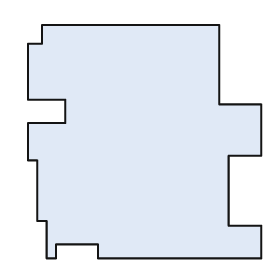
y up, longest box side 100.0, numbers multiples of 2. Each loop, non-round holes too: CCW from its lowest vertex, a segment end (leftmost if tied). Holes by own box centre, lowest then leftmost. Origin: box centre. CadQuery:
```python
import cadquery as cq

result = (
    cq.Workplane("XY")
    .moveTo(-42.0, -50.0)
    .lineTo(-38.0, -50.0)
    .lineTo(-38.0, -44.0)
    .lineTo(-20.0, -44.0)
    .lineTo(-20.0, -50.0)
    .lineTo(50.0, -50.0)
    .lineTo(50.0, -36.0)
    .lineTo(36.0, -36.0)
    .lineTo(36.0, -6.0)
    .lineTo(50.0, -6.0)
    .lineTo(50.0, 16.0)
    .lineTo(32.0, 16.0)
    .lineTo(32.0, 50.0)
    .lineTo(-44.0, 50.0)
    .lineTo(-44.0, 42.0)
    .lineTo(-50.0, 42.0)
    .lineTo(-50.0, 18.0)
    .lineTo(-34.0, 18.0)
    .lineTo(-34.0, 8.0)
    .lineTo(-50.0, 8.0)
    .lineTo(-50.0, -8.0)
    .lineTo(-46.0, -8.0)
    .lineTo(-46.0, -34.0)
    .lineTo(-42.0, -34.0)
    .close()
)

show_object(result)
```